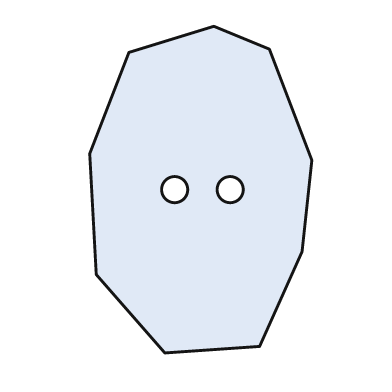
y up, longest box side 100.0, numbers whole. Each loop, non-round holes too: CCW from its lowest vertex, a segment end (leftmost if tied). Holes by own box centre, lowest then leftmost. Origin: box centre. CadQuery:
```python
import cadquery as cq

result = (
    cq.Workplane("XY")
    .moveTo(-11.0, -50.0)
    .lineTo(18.0, -48.0)
    .lineTo(31.0, -19.0)
    .lineTo(34.0, 9.0)
    .lineTo(21.0, 43.0)
    .lineTo(4.0, 50.0)
    .lineTo(-22.0, 42.0)
    .lineTo(-34.0, 11.0)
    .lineTo(-32.0, -26.0)
    .close()
    .moveTo(-8.0, 0.0)
    .circle(4.0)
    .moveTo(9.0, 0.0)
    .circle(4.0)
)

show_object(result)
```